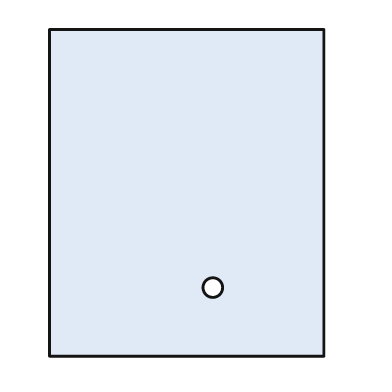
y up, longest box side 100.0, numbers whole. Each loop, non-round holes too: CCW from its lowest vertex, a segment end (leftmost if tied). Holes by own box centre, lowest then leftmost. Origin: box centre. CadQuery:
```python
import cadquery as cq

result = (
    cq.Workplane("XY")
    .moveTo(-42.0, -50.0)
    .lineTo(42.0, -50.0)
    .lineTo(42.0, 50.0)
    .lineTo(-42.0, 50.0)
    .close()
    .moveTo(8.0, -29.0)
    .circle(3.0)
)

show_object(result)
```